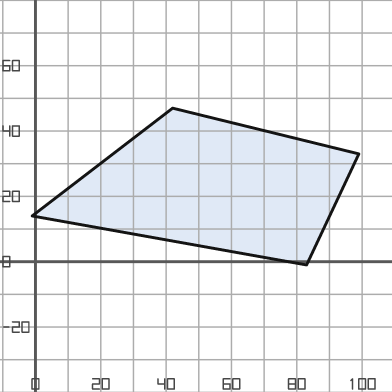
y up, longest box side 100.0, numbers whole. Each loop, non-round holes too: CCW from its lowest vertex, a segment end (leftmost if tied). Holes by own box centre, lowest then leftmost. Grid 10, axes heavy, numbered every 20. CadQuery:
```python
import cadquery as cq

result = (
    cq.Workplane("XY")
    .moveTo(83.0, -1.0)
    .lineTo(99.0, 33.0)
    .lineTo(42.0, 47.0)
    .lineTo(-1.0, 14.0)
    .close()
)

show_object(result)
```